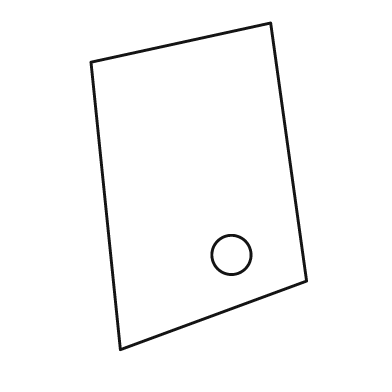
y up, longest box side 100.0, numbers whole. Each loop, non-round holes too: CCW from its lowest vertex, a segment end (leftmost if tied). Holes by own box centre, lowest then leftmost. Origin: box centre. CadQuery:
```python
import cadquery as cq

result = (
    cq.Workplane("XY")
    .moveTo(-24.0, -50.0)
    .lineTo(33.0, -29.0)
    .lineTo(22.0, 50.0)
    .lineTo(-33.0, 38.0)
    .close()
    .moveTo(10.0, -21.0)
    .circle(6.0)
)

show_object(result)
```